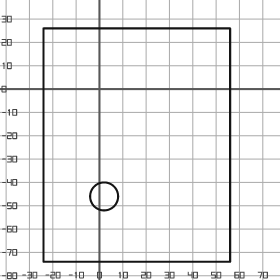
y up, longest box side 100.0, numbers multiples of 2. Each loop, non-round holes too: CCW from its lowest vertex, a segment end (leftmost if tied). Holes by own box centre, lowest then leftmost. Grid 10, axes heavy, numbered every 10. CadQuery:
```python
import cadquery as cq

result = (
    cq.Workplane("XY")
    .moveTo(-24.0, -74.0)
    .lineTo(56.0, -74.0)
    .lineTo(56.0, 26.0)
    .lineTo(-24.0, 26.0)
    .close()
    .moveTo(2.0, -46.0)
    .circle(6.0)
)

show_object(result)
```